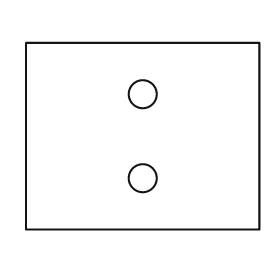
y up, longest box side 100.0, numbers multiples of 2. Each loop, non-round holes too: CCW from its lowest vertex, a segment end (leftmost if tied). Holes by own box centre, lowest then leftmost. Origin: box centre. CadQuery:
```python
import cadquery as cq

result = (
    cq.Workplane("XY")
    .moveTo(-50.0, -40.0)
    .lineTo(50.0, -40.0)
    .lineTo(50.0, 40.0)
    .lineTo(-50.0, 40.0)
    .close()
    .moveTo(0.0, -18.0)
    .circle(6.0)
    .moveTo(0.0, 18.0)
    .circle(6.0)
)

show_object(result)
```